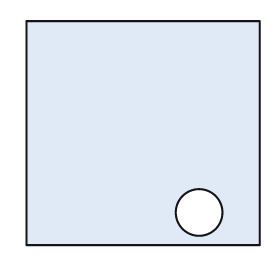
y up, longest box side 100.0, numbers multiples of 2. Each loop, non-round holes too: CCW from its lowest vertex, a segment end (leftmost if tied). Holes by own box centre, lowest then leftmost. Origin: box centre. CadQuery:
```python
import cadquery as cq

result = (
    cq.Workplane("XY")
    .moveTo(-50.0, -48.0)
    .lineTo(50.0, -48.0)
    .lineTo(50.0, 48.0)
    .lineTo(-50.0, 48.0)
    .close()
    .moveTo(24.0, -34.0)
    .circle(10.0)
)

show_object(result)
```